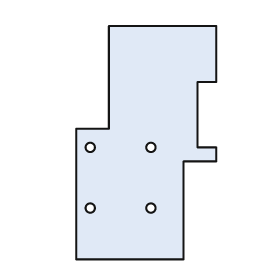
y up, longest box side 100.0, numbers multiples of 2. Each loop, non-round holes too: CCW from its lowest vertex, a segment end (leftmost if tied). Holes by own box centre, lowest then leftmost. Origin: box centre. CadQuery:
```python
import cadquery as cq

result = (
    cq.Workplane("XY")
    .moveTo(-30.0, -50.0)
    .lineTo(16.0, -50.0)
    .lineTo(16.0, -8.0)
    .lineTo(30.0, -8.0)
    .lineTo(30.0, -2.0)
    .lineTo(22.0, -2.0)
    .lineTo(22.0, 26.0)
    .lineTo(30.0, 26.0)
    .lineTo(30.0, 50.0)
    .lineTo(-16.0, 50.0)
    .lineTo(-16.0, 6.0)
    .lineTo(-30.0, 6.0)
    .close()
    .moveTo(-24.0, -28.0)
    .circle(2.0)
    .moveTo(2.0, -28.0)
    .circle(2.0)
    .moveTo(-24.0, -2.0)
    .circle(2.0)
    .moveTo(2.0, -2.0)
    .circle(2.0)
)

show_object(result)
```